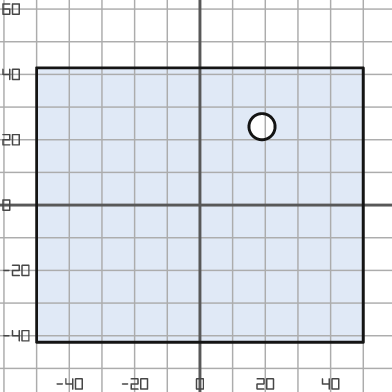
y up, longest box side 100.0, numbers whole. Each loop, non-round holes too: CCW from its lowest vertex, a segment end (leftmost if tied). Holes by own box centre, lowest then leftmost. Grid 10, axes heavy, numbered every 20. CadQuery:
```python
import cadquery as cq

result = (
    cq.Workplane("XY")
    .moveTo(-50.0, -42.0)
    .lineTo(50.0, -42.0)
    .lineTo(50.0, 42.0)
    .lineTo(-50.0, 42.0)
    .close()
    .moveTo(19.0, 24.0)
    .circle(4.0)
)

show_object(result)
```